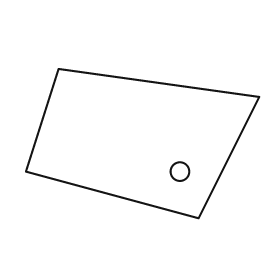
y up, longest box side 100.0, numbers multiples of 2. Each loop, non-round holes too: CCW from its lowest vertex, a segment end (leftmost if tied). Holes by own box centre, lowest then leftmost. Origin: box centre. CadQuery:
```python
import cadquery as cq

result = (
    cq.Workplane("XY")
    .moveTo(24.0, -32.0)
    .lineTo(50.0, 20.0)
    .lineTo(-36.0, 32.0)
    .lineTo(-50.0, -12.0)
    .close()
    .moveTo(16.0, -12.0)
    .circle(4.0)
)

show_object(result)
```